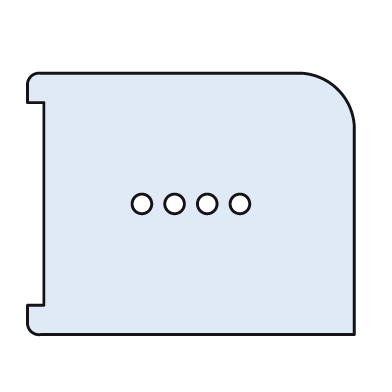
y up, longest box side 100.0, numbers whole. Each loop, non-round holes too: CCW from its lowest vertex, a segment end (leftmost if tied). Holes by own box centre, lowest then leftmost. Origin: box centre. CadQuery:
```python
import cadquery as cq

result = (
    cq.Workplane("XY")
    .moveTo(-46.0, -40.0)
    .lineTo(50.0, -40.0)
    .lineTo(50.0, 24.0)
    .threePointArc((45.0, 35.0), (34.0, 40.0))
    .lineTo(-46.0, 40.0)
    .threePointArc((-49.0, 39.0), (-50.0, 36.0))
    .lineTo(-50.0, 31.0)
    .lineTo(-45.0, 31.0)
    .lineTo(-45.0, -31.0)
    .lineTo(-50.0, -31.0)
    .lineTo(-50.0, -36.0)
    .threePointArc((-49.0, -39.0), (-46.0, -40.0))
    .close()
    .moveTo(-15.0, 0.0)
    .circle(3.0)
    .moveTo(-5.0, 0.0)
    .circle(3.0)
    .moveTo(5.0, 0.0)
    .circle(3.0)
    .moveTo(15.0, 0.0)
    .circle(3.0)
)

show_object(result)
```